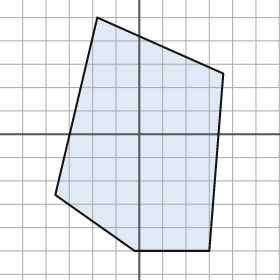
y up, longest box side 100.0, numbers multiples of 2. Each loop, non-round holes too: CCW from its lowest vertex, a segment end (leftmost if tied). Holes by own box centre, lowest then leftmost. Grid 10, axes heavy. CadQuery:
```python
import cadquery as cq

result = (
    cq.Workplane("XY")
    .moveTo(-2.0, -50.0)
    .lineTo(30.0, -50.0)
    .lineTo(36.0, 26.0)
    .lineTo(-18.0, 50.0)
    .lineTo(-36.0, -26.0)
    .close()
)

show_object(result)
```